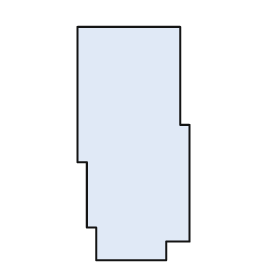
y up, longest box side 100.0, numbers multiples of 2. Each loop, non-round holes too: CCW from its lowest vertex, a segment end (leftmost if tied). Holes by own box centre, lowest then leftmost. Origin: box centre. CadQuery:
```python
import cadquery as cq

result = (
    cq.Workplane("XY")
    .moveTo(-16.0, -50.0)
    .lineTo(14.0, -50.0)
    .lineTo(14.0, -42.0)
    .lineTo(24.0, -42.0)
    .lineTo(24.0, 8.0)
    .lineTo(20.0, 8.0)
    .lineTo(20.0, 50.0)
    .lineTo(-24.0, 50.0)
    .lineTo(-24.0, -8.0)
    .lineTo(-20.0, -8.0)
    .lineTo(-20.0, -36.0)
    .lineTo(-16.0, -36.0)
    .close()
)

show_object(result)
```